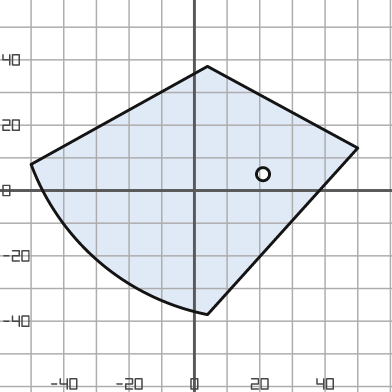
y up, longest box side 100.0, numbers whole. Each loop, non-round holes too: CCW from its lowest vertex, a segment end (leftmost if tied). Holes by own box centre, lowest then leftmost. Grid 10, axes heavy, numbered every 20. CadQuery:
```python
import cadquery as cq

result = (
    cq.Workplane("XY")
    .moveTo(4.0, -38.0)
    .lineTo(50.0, 13.0)
    .lineTo(4.0, 38.0)
    .lineTo(-50.0, 8.0)
    .threePointArc((-29.0, -22.0), (4.0, -38.0))
    .close()
    .moveTo(21.0, 5.0)
    .circle(2.0)
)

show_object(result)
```